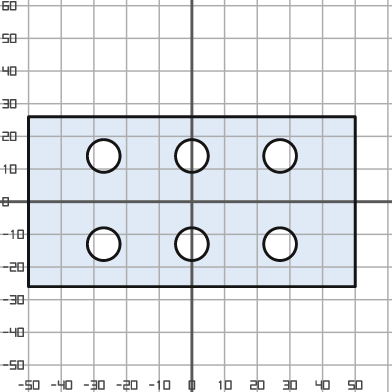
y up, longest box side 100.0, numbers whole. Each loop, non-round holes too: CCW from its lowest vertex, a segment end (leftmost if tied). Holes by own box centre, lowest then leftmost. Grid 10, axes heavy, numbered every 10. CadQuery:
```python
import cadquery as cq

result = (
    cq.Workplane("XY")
    .moveTo(-50.0, -26.0)
    .lineTo(50.0, -26.0)
    .lineTo(50.0, 26.0)
    .lineTo(-50.0, 26.0)
    .close()
    .moveTo(-27.0, -13.0)
    .circle(5.0)
    .moveTo(0.0, -13.0)
    .circle(5.0)
    .moveTo(27.0, -13.0)
    .circle(5.0)
    .moveTo(-27.0, 14.0)
    .circle(5.0)
    .moveTo(0.0, 14.0)
    .circle(5.0)
    .moveTo(27.0, 14.0)
    .circle(5.0)
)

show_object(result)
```